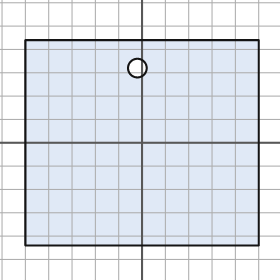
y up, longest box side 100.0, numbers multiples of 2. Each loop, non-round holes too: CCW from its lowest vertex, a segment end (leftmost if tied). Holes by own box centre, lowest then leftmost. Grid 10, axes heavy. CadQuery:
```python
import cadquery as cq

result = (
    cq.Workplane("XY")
    .moveTo(-50.0, -44.0)
    .lineTo(50.0, -44.0)
    .lineTo(50.0, 44.0)
    .lineTo(-50.0, 44.0)
    .close()
    .moveTo(-2.0, 32.0)
    .circle(4.0)
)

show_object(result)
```